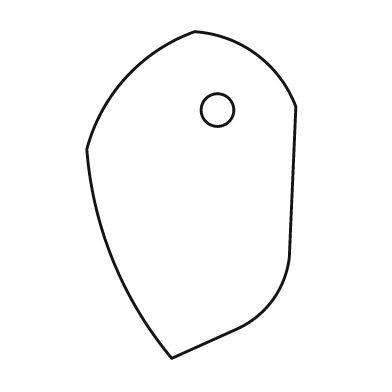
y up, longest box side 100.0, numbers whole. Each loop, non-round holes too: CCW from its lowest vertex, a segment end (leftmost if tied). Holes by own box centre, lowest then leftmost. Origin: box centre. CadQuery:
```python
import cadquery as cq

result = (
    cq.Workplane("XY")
    .moveTo(-6.0, -50.0)
    .lineTo(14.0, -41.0)
    .threePointArc((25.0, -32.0), (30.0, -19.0))
    .lineTo(32.0, 27.0)
    .threePointArc((20.0, 43.0), (1.0, 50.0))
    .threePointArc((-20.0, 36.0), (-32.0, 14.0))
    .threePointArc((-24.0, -20.0), (-6.0, -50.0))
    .close()
    .moveTo(8.0, 26.0)
    .circle(5.0)
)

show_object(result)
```